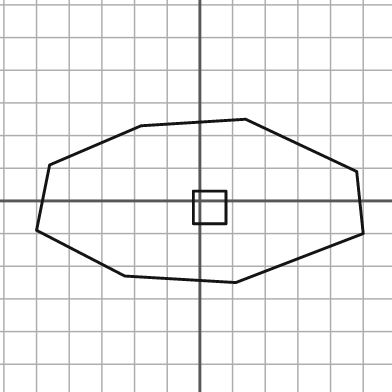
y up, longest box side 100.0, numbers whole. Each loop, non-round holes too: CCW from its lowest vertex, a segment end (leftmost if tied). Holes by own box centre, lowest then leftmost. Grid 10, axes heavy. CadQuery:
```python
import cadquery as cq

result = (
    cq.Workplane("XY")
    .moveTo(11.0, -25.0)
    .lineTo(50.0, -10.0)
    .lineTo(48.0, 9.0)
    .lineTo(14.0, 25.0)
    .lineTo(-18.0, 23.0)
    .lineTo(-46.0, 11.0)
    .lineTo(-50.0, -9.0)
    .lineTo(-23.0, -23.0)
    .close()
    .moveTo(-2.0, -7.0)
    .lineTo(8.0, -7.0)
    .lineTo(8.0, 3.0)
    .lineTo(-2.0, 3.0)
    .close()
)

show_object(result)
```